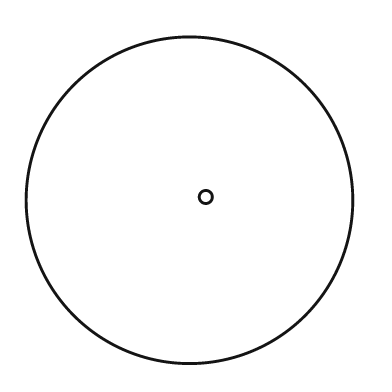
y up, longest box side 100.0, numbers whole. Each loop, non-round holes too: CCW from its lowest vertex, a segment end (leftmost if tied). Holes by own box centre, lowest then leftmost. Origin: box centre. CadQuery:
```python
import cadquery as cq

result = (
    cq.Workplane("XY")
    .moveTo(0.0, 0.0)
    .circle(50.0)
    .moveTo(5.0, 1.0)
    .circle(2.0)
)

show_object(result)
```